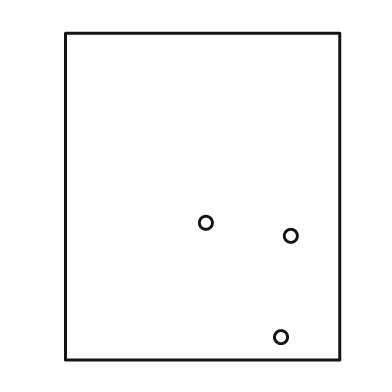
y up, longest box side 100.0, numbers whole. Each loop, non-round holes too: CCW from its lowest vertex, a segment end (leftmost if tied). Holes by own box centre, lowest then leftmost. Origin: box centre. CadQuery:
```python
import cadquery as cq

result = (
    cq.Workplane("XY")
    .moveTo(-42.0, -50.0)
    .lineTo(42.0, -50.0)
    .lineTo(42.0, 50.0)
    .lineTo(-42.0, 50.0)
    .close()
    .moveTo(24.0, -43.0)
    .circle(2.0)
    .moveTo(27.0, -12.0)
    .circle(2.0)
    .moveTo(1.0, -8.0)
    .circle(2.0)
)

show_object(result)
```